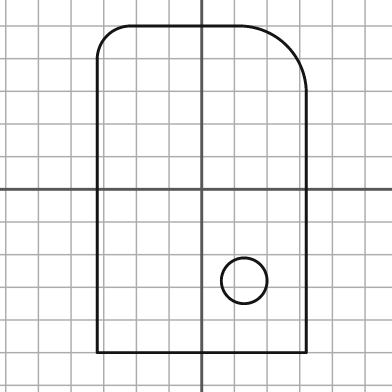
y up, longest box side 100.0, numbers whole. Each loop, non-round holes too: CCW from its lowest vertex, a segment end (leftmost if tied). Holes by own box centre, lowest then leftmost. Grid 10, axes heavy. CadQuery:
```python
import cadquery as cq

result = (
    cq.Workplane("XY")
    .moveTo(-32.0, -50.0)
    .lineTo(32.0, -50.0)
    .lineTo(32.0, 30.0)
    .threePointArc((26.0, 44.0), (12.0, 50.0))
    .lineTo(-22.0, 50.0)
    .threePointArc((-29.0, 47.0), (-32.0, 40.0))
    .close()
    .moveTo(13.0, -28.0)
    .circle(7.0)
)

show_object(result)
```